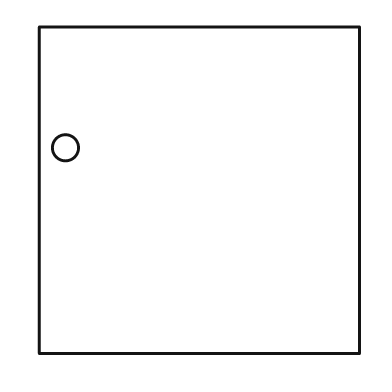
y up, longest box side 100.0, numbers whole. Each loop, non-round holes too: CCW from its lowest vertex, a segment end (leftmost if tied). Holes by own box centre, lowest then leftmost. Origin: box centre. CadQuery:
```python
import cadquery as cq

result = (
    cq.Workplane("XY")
    .moveTo(-49.0, -50.0)
    .lineTo(49.0, -50.0)
    .lineTo(49.0, 50.0)
    .lineTo(-49.0, 50.0)
    .close()
    .moveTo(-41.0, 13.0)
    .circle(4.0)
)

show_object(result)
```